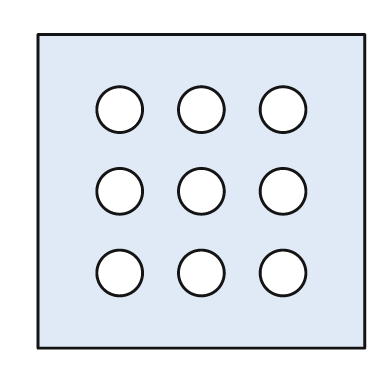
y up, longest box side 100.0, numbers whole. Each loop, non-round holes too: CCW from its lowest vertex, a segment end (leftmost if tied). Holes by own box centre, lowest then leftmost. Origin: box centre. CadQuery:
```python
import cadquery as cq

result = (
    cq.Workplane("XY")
    .moveTo(-50.0, -48.0)
    .lineTo(50.0, -48.0)
    .lineTo(50.0, 48.0)
    .lineTo(-50.0, 48.0)
    .close()
    .moveTo(-25.0, -25.0)
    .circle(7.0)
    .moveTo(0.0, -25.0)
    .circle(7.0)
    .moveTo(25.0, -25.0)
    .circle(7.0)
    .moveTo(-25.0, 0.0)
    .circle(7.0)
    .moveTo(0.0, 0.0)
    .circle(7.0)
    .moveTo(25.0, 0.0)
    .circle(7.0)
    .moveTo(-25.0, 25.0)
    .circle(7.0)
    .moveTo(0.0, 25.0)
    .circle(7.0)
    .moveTo(25.0, 25.0)
    .circle(7.0)
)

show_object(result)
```